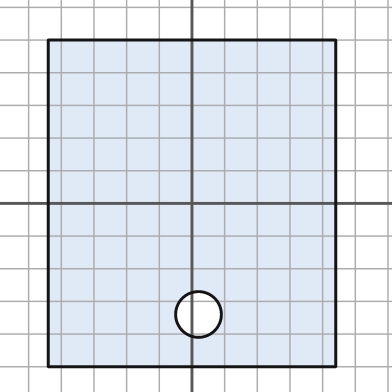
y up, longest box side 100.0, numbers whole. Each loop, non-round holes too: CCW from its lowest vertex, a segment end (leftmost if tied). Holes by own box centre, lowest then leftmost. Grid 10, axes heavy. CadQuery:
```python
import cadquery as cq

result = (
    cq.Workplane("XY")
    .moveTo(-44.0, -50.0)
    .lineTo(44.0, -50.0)
    .lineTo(44.0, 50.0)
    .lineTo(-44.0, 50.0)
    .close()
    .moveTo(2.0, -34.0)
    .circle(7.0)
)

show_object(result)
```